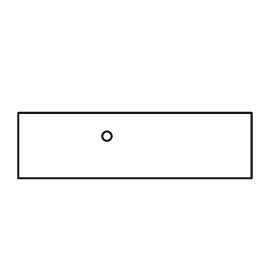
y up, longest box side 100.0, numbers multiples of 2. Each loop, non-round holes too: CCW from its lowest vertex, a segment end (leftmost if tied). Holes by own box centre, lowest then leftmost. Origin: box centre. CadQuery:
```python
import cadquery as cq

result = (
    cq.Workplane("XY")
    .moveTo(-50.0, -14.0)
    .lineTo(50.0, -14.0)
    .lineTo(50.0, 14.0)
    .lineTo(-50.0, 14.0)
    .close()
    .moveTo(-12.0, 4.0)
    .circle(2.0)
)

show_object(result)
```